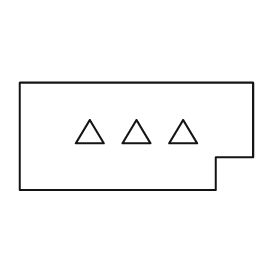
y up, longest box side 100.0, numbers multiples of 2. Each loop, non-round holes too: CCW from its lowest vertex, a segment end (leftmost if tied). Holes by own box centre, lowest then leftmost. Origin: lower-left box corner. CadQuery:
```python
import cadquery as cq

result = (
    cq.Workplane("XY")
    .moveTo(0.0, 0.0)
    .lineTo(84.0, 0.0)
    .lineTo(84.0, 14.0)
    .lineTo(100.0, 14.0)
    .lineTo(100.0, 46.0)
    .lineTo(0.0, 46.0)
    .close()
    .moveTo(24.0, 20.0)
    .lineTo(36.0, 20.0)
    .lineTo(30.0, 30.0)
    .close()
    .moveTo(44.0, 20.0)
    .lineTo(56.0, 20.0)
    .lineTo(50.0, 30.0)
    .close()
    .moveTo(64.0, 20.0)
    .lineTo(76.0, 20.0)
    .lineTo(70.0, 30.0)
    .close()
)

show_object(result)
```